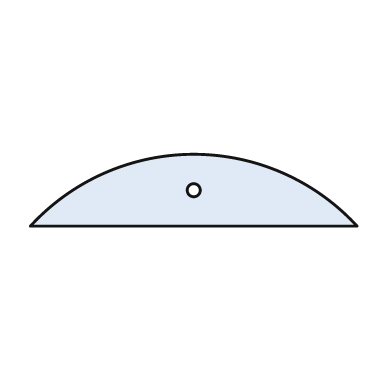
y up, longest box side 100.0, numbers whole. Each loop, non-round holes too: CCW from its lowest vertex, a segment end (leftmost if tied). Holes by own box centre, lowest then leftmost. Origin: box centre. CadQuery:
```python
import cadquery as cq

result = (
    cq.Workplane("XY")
    .moveTo(-50.0, -11.0)
    .lineTo(50.0, -11.0)
    .threePointArc((0.0, 11.0), (-50.0, -11.0))
    .close()
    .moveTo(0.0, 0.0)
    .circle(2.0)
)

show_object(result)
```